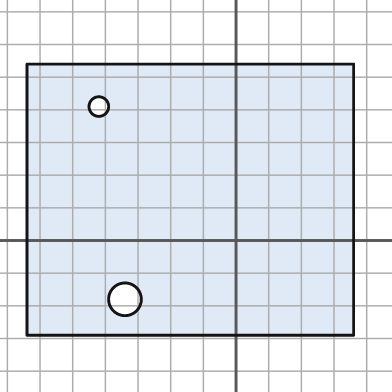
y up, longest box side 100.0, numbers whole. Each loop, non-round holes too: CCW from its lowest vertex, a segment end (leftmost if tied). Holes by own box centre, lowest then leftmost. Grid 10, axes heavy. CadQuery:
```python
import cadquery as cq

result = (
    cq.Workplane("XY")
    .moveTo(-64.0, -29.0)
    .lineTo(36.0, -29.0)
    .lineTo(36.0, 54.0)
    .lineTo(-64.0, 54.0)
    .close()
    .moveTo(-34.0, -18.0)
    .circle(5.0)
    .moveTo(-42.0, 41.0)
    .circle(3.0)
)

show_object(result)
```